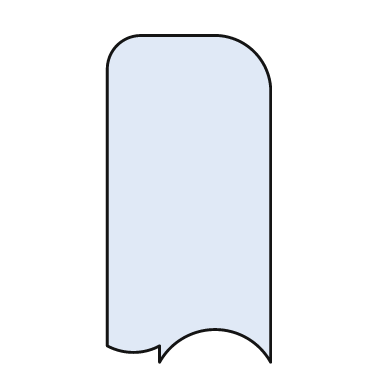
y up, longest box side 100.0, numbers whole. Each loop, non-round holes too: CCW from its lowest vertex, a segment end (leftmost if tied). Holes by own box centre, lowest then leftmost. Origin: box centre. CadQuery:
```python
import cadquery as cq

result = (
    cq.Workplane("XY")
    .moveTo(-9.0, -50.0)
    .threePointArc((8.0, -40.0), (25.0, -50.0))
    .lineTo(25.0, 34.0)
    .threePointArc((20.0, 45.0), (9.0, 50.0))
    .lineTo(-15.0, 50.0)
    .threePointArc((-22.0, 47.0), (-25.0, 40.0))
    .lineTo(-25.0, -45.0)
    .threePointArc((-17.0, -47.0), (-9.0, -45.0))
    .close()
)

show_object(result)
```